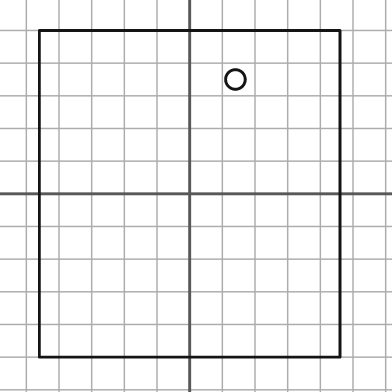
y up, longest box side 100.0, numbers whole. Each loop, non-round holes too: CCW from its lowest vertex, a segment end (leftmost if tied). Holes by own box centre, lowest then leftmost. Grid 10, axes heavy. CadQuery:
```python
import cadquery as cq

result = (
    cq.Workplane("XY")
    .moveTo(-46.0, -50.0)
    .lineTo(46.0, -50.0)
    .lineTo(46.0, 50.0)
    .lineTo(-46.0, 50.0)
    .close()
    .moveTo(14.0, 35.0)
    .circle(3.0)
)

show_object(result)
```